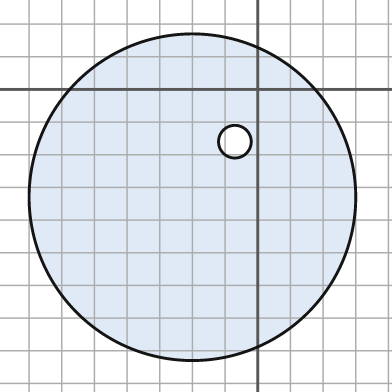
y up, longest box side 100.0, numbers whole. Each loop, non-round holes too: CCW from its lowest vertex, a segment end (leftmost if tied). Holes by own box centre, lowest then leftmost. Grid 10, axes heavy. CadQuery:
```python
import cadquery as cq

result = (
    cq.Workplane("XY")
    .moveTo(-20.0, -33.0)
    .circle(50.0)
    .moveTo(-7.0, -16.0)
    .circle(5.0)
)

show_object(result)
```